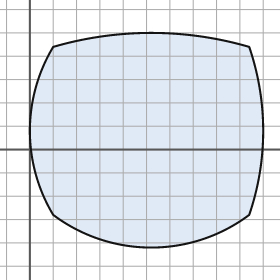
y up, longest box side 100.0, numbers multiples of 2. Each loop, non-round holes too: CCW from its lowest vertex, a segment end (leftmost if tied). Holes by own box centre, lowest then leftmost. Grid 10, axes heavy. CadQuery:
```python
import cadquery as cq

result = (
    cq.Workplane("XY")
    .moveTo(10.0, -28.0)
    .threePointArc((52.0, -42.0), (94.0, -28.0))
    .threePointArc((100.0, 8.0), (94.0, 44.0))
    .threePointArc((52.0, 50.0), (10.0, 44.0))
    .threePointArc((0.0, 8.0), (10.0, -28.0))
    .close()
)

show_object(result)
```